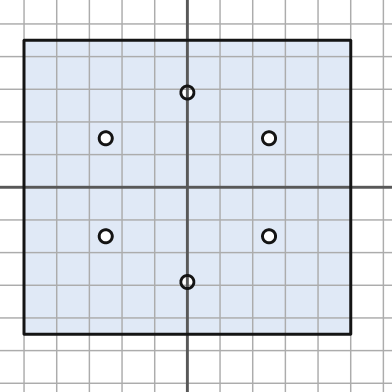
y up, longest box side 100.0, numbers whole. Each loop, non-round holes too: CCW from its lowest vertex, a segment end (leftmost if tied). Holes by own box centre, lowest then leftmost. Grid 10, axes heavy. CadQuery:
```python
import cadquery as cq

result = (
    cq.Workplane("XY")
    .moveTo(-50.0, -45.0)
    .lineTo(50.0, -45.0)
    .lineTo(50.0, 45.0)
    .lineTo(-50.0, 45.0)
    .close()
    .moveTo(0.0, -29.0)
    .circle(2.0)
    .moveTo(-25.0, -15.0)
    .circle(2.0)
    .moveTo(25.0, -15.0)
    .circle(2.0)
    .moveTo(-25.0, 15.0)
    .circle(2.0)
    .moveTo(25.0, 15.0)
    .circle(2.0)
    .moveTo(0.0, 29.0)
    .circle(2.0)
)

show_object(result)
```